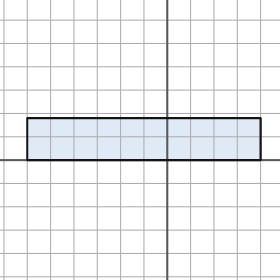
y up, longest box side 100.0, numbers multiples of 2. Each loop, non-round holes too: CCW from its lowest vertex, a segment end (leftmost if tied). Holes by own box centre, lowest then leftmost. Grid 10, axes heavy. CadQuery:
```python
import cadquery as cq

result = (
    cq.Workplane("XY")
    .moveTo(-60.0, 0.0)
    .lineTo(40.0, 0.0)
    .lineTo(40.0, 18.0)
    .lineTo(-60.0, 18.0)
    .close()
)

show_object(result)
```